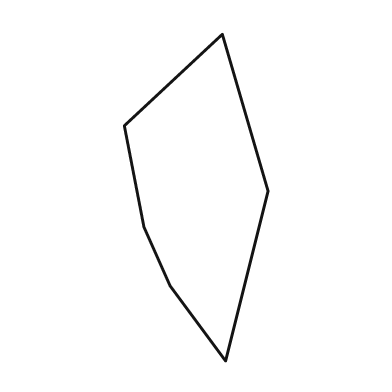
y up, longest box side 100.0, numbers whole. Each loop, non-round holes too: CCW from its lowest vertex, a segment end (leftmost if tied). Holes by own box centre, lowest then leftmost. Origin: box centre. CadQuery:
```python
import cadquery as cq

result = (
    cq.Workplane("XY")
    .moveTo(9.0, -50.0)
    .lineTo(22.0, 2.0)
    .lineTo(8.0, 50.0)
    .lineTo(-22.0, 22.0)
    .lineTo(-16.0, -9.0)
    .lineTo(-8.0, -27.0)
    .close()
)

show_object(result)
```